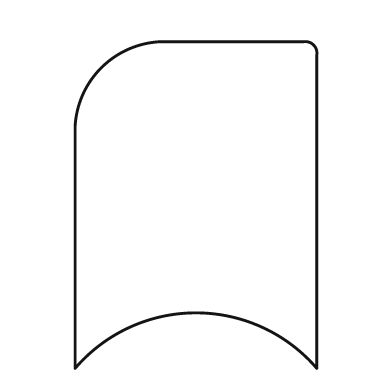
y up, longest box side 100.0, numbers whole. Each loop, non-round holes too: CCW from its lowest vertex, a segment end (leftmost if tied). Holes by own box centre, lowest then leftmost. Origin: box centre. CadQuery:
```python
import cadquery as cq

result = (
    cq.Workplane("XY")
    .moveTo(-37.0, -50.0)
    .threePointArc((0.0, -33.0), (37.0, -50.0))
    .lineTo(37.0, 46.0)
    .threePointArc((36.0, 49.0), (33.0, 50.0))
    .lineTo(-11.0, 50.0)
    .threePointArc((-29.0, 42.0), (-37.0, 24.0))
    .close()
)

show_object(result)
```